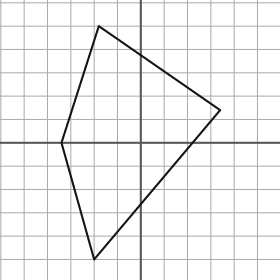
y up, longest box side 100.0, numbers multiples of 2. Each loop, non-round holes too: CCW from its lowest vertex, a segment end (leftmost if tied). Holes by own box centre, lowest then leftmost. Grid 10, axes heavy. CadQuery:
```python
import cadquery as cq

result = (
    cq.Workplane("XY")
    .moveTo(-20.0, -50.0)
    .lineTo(34.0, 14.0)
    .lineTo(-18.0, 50.0)
    .lineTo(-34.0, 0.0)
    .close()
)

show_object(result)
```